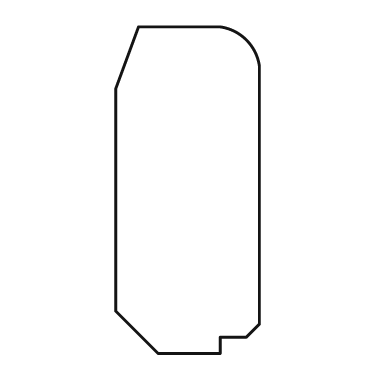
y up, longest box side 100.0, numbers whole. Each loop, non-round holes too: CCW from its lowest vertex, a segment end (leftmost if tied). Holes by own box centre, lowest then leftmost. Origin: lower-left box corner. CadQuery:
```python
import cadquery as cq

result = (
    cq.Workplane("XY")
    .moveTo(13.0, 0.0)
    .lineTo(32.0, 0.0)
    .lineTo(32.0, 5.0)
    .lineTo(40.0, 5.0)
    .lineTo(44.0, 9.0)
    .lineTo(44.0, 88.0)
    .threePointArc((40.0, 96.0), (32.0, 100.0))
    .lineTo(7.0, 100.0)
    .lineTo(0.0, 81.0)
    .lineTo(0.0, 13.0)
    .close()
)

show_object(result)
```